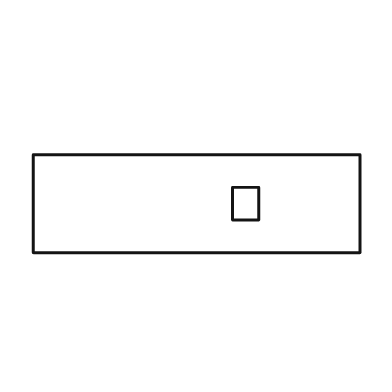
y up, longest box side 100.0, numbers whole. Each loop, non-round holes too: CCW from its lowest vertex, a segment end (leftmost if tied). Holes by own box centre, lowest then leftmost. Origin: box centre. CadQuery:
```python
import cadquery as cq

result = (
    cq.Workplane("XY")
    .moveTo(-50.0, -15.0)
    .lineTo(50.0, -15.0)
    .lineTo(50.0, 15.0)
    .lineTo(-50.0, 15.0)
    .close()
    .moveTo(11.0, -5.0)
    .lineTo(19.0, -5.0)
    .lineTo(19.0, 5.0)
    .lineTo(11.0, 5.0)
    .close()
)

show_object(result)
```